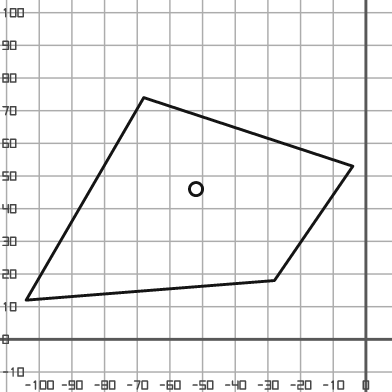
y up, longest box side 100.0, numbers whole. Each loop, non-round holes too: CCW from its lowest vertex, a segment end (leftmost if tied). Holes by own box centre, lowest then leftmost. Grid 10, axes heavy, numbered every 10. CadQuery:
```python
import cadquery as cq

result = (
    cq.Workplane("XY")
    .moveTo(-104.0, 12.0)
    .lineTo(-28.0, 18.0)
    .lineTo(-4.0, 53.0)
    .lineTo(-68.0, 74.0)
    .close()
    .moveTo(-52.0, 46.0)
    .circle(2.0)
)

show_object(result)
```